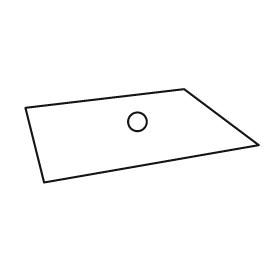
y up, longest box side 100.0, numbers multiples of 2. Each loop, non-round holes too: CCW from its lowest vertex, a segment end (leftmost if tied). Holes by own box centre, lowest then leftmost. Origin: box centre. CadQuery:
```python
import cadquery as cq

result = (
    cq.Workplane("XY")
    .moveTo(-42.0, -20.0)
    .lineTo(50.0, -4.0)
    .lineTo(18.0, 20.0)
    .lineTo(-50.0, 12.0)
    .close()
    .moveTo(-2.0, 6.0)
    .circle(4.0)
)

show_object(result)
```